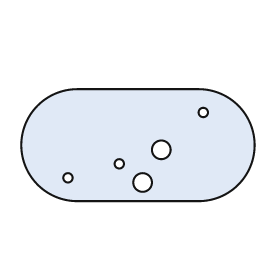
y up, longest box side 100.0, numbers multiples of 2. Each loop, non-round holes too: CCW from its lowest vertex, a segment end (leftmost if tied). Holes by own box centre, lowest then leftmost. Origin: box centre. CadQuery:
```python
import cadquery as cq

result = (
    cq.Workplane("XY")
    .moveTo(-26.0, -24.0)
    .lineTo(26.0, -24.0)
    .threePointArc((50.0, 0.0), (26.0, 24.0))
    .lineTo(-26.0, 24.0)
    .threePointArc((-50.0, 0.0), (-26.0, -24.0))
    .close()
    .moveTo(2.0, -16.0)
    .circle(4.0)
    .moveTo(-30.0, -14.0)
    .circle(2.0)
    .moveTo(-8.0, -8.0)
    .circle(2.0)
    .moveTo(10.0, -2.0)
    .circle(4.0)
    .moveTo(28.0, 14.0)
    .circle(2.0)
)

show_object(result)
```